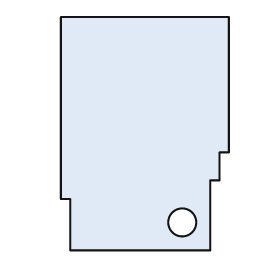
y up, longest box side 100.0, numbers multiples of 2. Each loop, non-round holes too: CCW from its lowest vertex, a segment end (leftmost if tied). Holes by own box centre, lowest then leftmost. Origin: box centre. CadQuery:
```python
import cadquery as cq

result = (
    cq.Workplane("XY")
    .moveTo(-32.0, -50.0)
    .lineTo(28.0, -50.0)
    .lineTo(28.0, -20.0)
    .lineTo(32.0, -20.0)
    .lineTo(32.0, -8.0)
    .lineTo(36.0, -8.0)
    .lineTo(36.0, 50.0)
    .lineTo(-36.0, 50.0)
    .lineTo(-36.0, -28.0)
    .lineTo(-32.0, -28.0)
    .close()
    .moveTo(16.0, -38.0)
    .circle(6.0)
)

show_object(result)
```